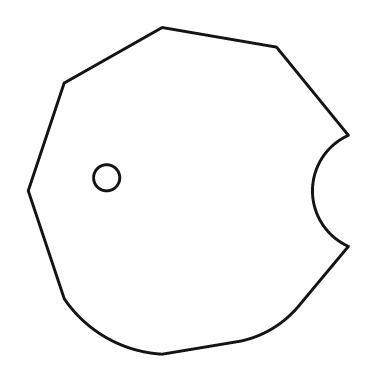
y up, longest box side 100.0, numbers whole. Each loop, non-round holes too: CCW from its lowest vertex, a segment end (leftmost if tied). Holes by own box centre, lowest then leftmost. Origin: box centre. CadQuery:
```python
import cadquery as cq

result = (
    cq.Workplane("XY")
    .moveTo(-8.0, -50.0)
    .lineTo(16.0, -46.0)
    .threePointArc((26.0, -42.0), (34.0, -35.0))
    .lineTo(49.0, -17.0)
    .threePointArc((38.0, 0.0), (49.0, 17.0))
    .lineTo(27.0, 44.0)
    .lineTo(-8.0, 50.0)
    .lineTo(-38.0, 33.0)
    .lineTo(-49.0, 0.0)
    .lineTo(-38.0, -33.0)
    .threePointArc((-25.0, -45.0), (-8.0, -50.0))
    .close()
    .moveTo(-25.0, 4.0)
    .circle(4.0)
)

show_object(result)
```